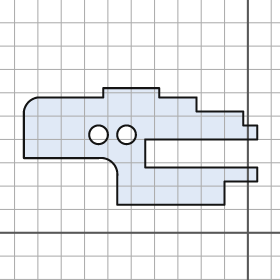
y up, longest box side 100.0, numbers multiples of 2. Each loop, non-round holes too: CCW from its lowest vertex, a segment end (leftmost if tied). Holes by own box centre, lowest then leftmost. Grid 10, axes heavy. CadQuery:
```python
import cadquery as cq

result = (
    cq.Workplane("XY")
    .moveTo(-56.0, 12.0)
    .lineTo(-10.0, 12.0)
    .lineTo(-10.0, 22.0)
    .lineTo(4.0, 22.0)
    .lineTo(4.0, 28.0)
    .lineTo(-44.0, 28.0)
    .lineTo(-44.0, 40.0)
    .lineTo(4.0, 40.0)
    .lineTo(4.0, 46.0)
    .lineTo(-2.0, 46.0)
    .lineTo(-2.0, 52.0)
    .lineTo(-22.0, 52.0)
    .lineTo(-22.0, 58.0)
    .lineTo(-38.0, 58.0)
    .lineTo(-38.0, 62.0)
    .lineTo(-62.0, 62.0)
    .lineTo(-62.0, 58.0)
    .lineTo(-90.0, 58.0)
    .threePointArc((-94.0, 56.0), (-96.0, 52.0))
    .lineTo(-96.0, 32.0)
    .lineTo(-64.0, 32.0)
    .threePointArc((-58.0, 30.0), (-56.0, 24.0))
    .close()
    .moveTo(-64.0, 42.0)
    .circle(4.0)
    .moveTo(-52.0, 42.0)
    .circle(4.0)
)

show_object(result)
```